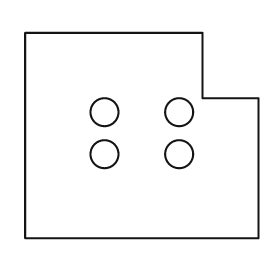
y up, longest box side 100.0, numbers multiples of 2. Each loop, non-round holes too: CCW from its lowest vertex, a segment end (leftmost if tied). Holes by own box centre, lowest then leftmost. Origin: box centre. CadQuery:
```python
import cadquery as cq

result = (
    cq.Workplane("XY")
    .moveTo(-50.0, -44.0)
    .lineTo(50.0, -44.0)
    .lineTo(50.0, 16.0)
    .lineTo(26.0, 16.0)
    .lineTo(26.0, 44.0)
    .lineTo(-50.0, 44.0)
    .close()
    .moveTo(-16.0, -8.0)
    .circle(6.0)
    .moveTo(16.0, -8.0)
    .circle(6.0)
    .moveTo(-16.0, 10.0)
    .circle(6.0)
    .moveTo(16.0, 10.0)
    .circle(6.0)
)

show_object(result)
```